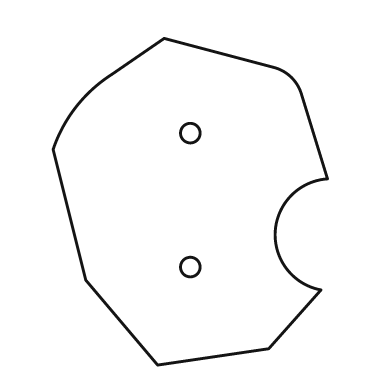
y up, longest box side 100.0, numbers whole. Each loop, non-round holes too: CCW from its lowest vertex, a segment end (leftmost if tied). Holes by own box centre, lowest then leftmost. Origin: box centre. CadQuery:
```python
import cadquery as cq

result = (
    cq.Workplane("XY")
    .moveTo(-10.0, -50.0)
    .lineTo(24.0, -45.0)
    .lineTo(40.0, -27.0)
    .threePointArc((26.0, -9.0), (42.0, 7.0))
    .lineTo(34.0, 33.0)
    .threePointArc((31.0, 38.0), (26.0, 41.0))
    .lineTo(-8.0, 50.0)
    .lineTo(-24.0, 39.0)
    .threePointArc((-35.0, 29.0), (-42.0, 16.0))
    .lineTo(-32.0, -24.0)
    .close()
    .moveTo(0.0, -20.0)
    .circle(3.0)
    .moveTo(0.0, 21.0)
    .circle(3.0)
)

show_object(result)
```